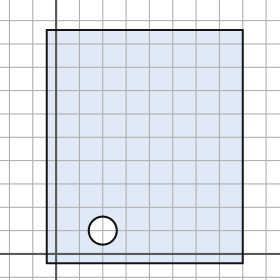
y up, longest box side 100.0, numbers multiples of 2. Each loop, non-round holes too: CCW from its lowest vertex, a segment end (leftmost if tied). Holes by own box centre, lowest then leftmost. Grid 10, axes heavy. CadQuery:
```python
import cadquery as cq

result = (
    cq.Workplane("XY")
    .moveTo(-4.0, -4.0)
    .lineTo(80.0, -4.0)
    .lineTo(80.0, 96.0)
    .lineTo(-4.0, 96.0)
    .close()
    .moveTo(20.0, 10.0)
    .circle(6.0)
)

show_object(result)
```